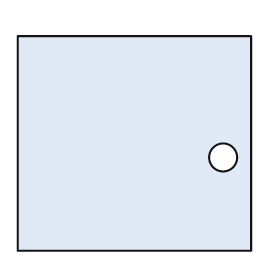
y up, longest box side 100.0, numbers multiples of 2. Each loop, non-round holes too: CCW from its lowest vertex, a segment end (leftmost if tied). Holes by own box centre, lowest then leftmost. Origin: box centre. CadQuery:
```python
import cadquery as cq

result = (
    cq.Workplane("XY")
    .moveTo(-50.0, -46.0)
    .lineTo(50.0, -46.0)
    .lineTo(50.0, 46.0)
    .lineTo(-50.0, 46.0)
    .close()
    .moveTo(38.0, -6.0)
    .circle(6.0)
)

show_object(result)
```